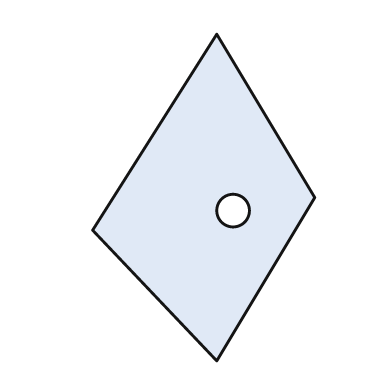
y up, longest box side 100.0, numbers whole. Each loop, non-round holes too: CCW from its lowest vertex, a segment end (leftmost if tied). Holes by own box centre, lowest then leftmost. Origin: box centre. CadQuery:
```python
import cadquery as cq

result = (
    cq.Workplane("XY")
    .moveTo(4.0, -50.0)
    .lineTo(34.0, 0.0)
    .lineTo(4.0, 50.0)
    .lineTo(-34.0, -10.0)
    .close()
    .moveTo(9.0, -4.0)
    .circle(5.0)
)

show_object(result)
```